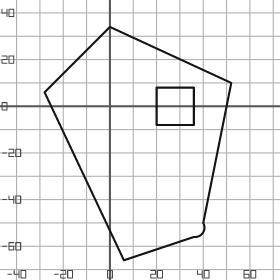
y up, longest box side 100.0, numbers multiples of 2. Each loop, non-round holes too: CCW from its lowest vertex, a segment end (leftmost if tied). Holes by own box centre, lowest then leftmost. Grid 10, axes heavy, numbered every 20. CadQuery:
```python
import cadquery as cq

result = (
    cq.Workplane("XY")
    .moveTo(6.0, -66.0)
    .lineTo(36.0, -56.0)
    .threePointArc((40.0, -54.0), (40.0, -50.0))
    .lineTo(52.0, 10.0)
    .lineTo(0.0, 34.0)
    .lineTo(-28.0, 6.0)
    .close()
    .moveTo(20.0, -8.0)
    .lineTo(36.0, -8.0)
    .lineTo(36.0, 8.0)
    .lineTo(20.0, 8.0)
    .close()
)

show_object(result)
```